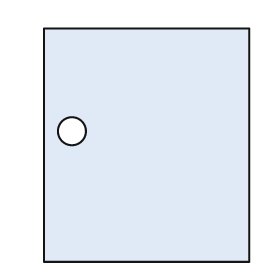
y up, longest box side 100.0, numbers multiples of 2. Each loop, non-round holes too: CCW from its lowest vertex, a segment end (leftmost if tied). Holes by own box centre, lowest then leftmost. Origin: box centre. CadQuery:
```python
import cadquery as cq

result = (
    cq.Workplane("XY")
    .moveTo(-44.0, -50.0)
    .lineTo(44.0, -50.0)
    .lineTo(44.0, 50.0)
    .lineTo(-44.0, 50.0)
    .close()
    .moveTo(-32.0, 6.0)
    .circle(6.0)
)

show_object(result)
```